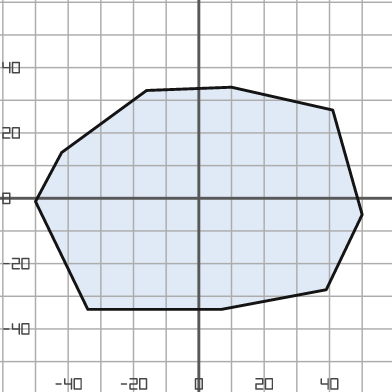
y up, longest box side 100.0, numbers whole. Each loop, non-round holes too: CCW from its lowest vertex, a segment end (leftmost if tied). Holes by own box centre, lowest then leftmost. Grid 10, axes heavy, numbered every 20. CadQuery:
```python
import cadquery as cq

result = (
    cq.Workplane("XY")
    .moveTo(-34.0, -34.0)
    .lineTo(7.0, -34.0)
    .lineTo(39.0, -28.0)
    .lineTo(50.0, -5.0)
    .lineTo(41.0, 27.0)
    .lineTo(10.0, 34.0)
    .lineTo(-16.0, 33.0)
    .lineTo(-42.0, 14.0)
    .lineTo(-50.0, -1.0)
    .close()
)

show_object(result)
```